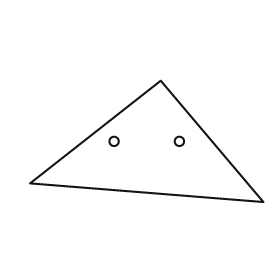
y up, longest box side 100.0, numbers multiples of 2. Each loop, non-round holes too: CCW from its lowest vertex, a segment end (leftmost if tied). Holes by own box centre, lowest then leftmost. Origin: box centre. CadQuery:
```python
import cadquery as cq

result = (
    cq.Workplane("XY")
    .moveTo(50.0, -26.0)
    .lineTo(6.0, 26.0)
    .lineTo(-50.0, -18.0)
    .close()
    .moveTo(-14.0, 0.0)
    .circle(2.0)
    .moveTo(14.0, 0.0)
    .circle(2.0)
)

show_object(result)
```